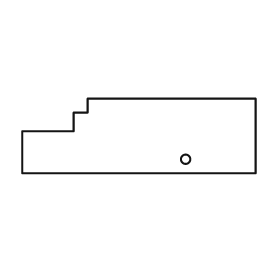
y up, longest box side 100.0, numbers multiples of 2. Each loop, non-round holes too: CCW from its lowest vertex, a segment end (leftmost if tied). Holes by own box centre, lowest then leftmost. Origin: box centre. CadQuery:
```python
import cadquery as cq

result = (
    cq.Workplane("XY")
    .moveTo(-50.0, -16.0)
    .lineTo(50.0, -16.0)
    .lineTo(50.0, 16.0)
    .lineTo(-22.0, 16.0)
    .lineTo(-22.0, 10.0)
    .lineTo(-28.0, 10.0)
    .lineTo(-28.0, 2.0)
    .lineTo(-50.0, 2.0)
    .close()
    .moveTo(20.0, -10.0)
    .circle(2.0)
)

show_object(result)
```